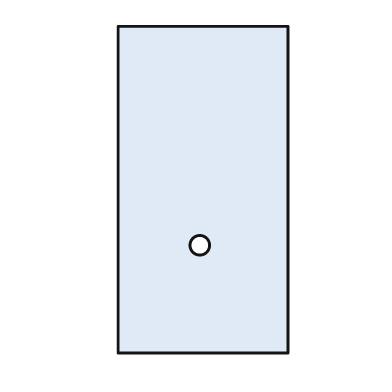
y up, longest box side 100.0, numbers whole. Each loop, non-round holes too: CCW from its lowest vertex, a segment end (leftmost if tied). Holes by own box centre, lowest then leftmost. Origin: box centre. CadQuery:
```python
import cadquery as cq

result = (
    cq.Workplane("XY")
    .moveTo(-26.0, -50.0)
    .lineTo(26.0, -50.0)
    .lineTo(26.0, 50.0)
    .lineTo(-26.0, 50.0)
    .close()
    .moveTo(-1.0, -17.0)
    .circle(3.0)
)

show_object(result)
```